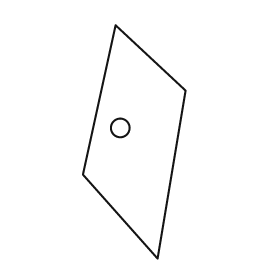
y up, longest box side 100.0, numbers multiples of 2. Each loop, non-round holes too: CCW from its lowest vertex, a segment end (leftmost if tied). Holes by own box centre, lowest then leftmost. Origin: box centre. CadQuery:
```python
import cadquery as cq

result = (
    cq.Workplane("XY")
    .moveTo(10.0, -50.0)
    .lineTo(22.0, 22.0)
    .lineTo(-8.0, 50.0)
    .lineTo(-22.0, -14.0)
    .close()
    .moveTo(-6.0, 6.0)
    .circle(4.0)
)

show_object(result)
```